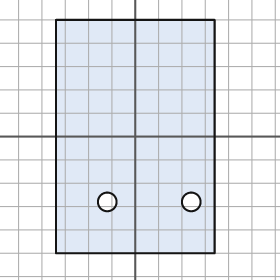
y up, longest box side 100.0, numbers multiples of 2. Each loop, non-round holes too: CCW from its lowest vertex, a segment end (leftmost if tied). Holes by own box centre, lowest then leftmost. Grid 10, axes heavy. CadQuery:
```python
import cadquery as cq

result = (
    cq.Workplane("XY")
    .moveTo(-34.0, -50.0)
    .lineTo(34.0, -50.0)
    .lineTo(34.0, 50.0)
    .lineTo(-34.0, 50.0)
    .close()
    .moveTo(-12.0, -28.0)
    .circle(4.0)
    .moveTo(24.0, -28.0)
    .circle(4.0)
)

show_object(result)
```